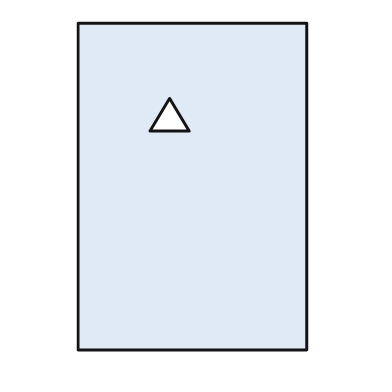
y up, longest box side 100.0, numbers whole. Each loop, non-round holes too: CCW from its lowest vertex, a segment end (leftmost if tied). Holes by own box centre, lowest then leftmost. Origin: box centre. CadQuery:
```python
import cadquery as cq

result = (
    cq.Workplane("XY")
    .moveTo(-35.0, -50.0)
    .lineTo(35.0, -50.0)
    .lineTo(35.0, 50.0)
    .lineTo(-35.0, 50.0)
    .close()
    .moveTo(-13.0, 17.0)
    .lineTo(-1.0, 17.0)
    .lineTo(-7.0, 27.0)
    .close()
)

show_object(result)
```